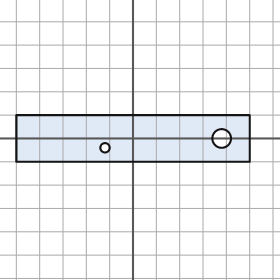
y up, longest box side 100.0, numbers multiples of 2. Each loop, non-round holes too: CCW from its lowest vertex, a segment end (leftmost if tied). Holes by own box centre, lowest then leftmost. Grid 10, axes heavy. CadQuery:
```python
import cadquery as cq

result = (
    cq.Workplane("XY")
    .moveTo(-50.0, -10.0)
    .lineTo(50.0, -10.0)
    .lineTo(50.0, 10.0)
    .lineTo(-50.0, 10.0)
    .close()
    .moveTo(-12.0, -4.0)
    .circle(2.0)
    .moveTo(38.0, 0.0)
    .circle(4.0)
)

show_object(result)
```